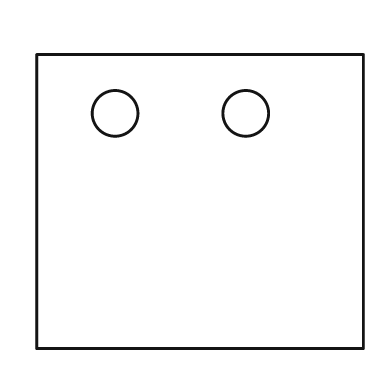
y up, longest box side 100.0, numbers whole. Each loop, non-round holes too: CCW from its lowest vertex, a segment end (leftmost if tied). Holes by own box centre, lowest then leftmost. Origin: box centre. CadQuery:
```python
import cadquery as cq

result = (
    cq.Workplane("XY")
    .moveTo(-50.0, -45.0)
    .lineTo(50.0, -45.0)
    .lineTo(50.0, 45.0)
    .lineTo(-50.0, 45.0)
    .close()
    .moveTo(-26.0, 27.0)
    .circle(7.0)
    .moveTo(14.0, 27.0)
    .circle(7.0)
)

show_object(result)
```